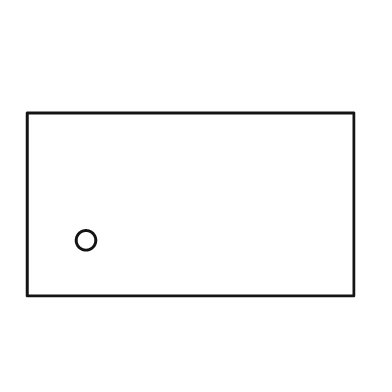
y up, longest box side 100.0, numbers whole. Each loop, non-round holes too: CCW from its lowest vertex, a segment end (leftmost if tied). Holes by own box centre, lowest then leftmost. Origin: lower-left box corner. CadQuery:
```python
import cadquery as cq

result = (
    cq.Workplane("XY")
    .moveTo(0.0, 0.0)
    .lineTo(100.0, 0.0)
    .lineTo(100.0, 56.0)
    .lineTo(0.0, 56.0)
    .close()
    .moveTo(18.0, 17.0)
    .circle(3.0)
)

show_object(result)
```